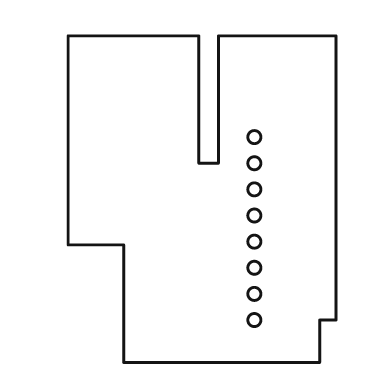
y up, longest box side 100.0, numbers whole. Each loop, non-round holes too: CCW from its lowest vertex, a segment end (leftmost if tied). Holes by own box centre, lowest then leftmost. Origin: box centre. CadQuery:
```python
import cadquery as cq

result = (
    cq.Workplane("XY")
    .moveTo(-24.0, -50.0)
    .lineTo(36.0, -50.0)
    .lineTo(36.0, -37.0)
    .lineTo(41.0, -37.0)
    .lineTo(41.0, 50.0)
    .lineTo(5.0, 50.0)
    .lineTo(5.0, 11.0)
    .lineTo(-1.0, 11.0)
    .lineTo(-1.0, 50.0)
    .lineTo(-41.0, 50.0)
    .lineTo(-41.0, -14.0)
    .lineTo(-24.0, -14.0)
    .close()
    .moveTo(16.0, -37.0)
    .circle(2.0)
    .moveTo(16.0, -29.0)
    .circle(2.0)
    .moveTo(16.0, -21.0)
    .circle(2.0)
    .moveTo(16.0, -13.0)
    .circle(2.0)
    .moveTo(16.0, -5.0)
    .circle(2.0)
    .moveTo(16.0, 3.0)
    .circle(2.0)
    .moveTo(16.0, 11.0)
    .circle(2.0)
    .moveTo(16.0, 19.0)
    .circle(2.0)
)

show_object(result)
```